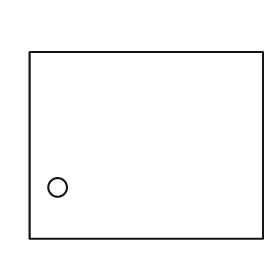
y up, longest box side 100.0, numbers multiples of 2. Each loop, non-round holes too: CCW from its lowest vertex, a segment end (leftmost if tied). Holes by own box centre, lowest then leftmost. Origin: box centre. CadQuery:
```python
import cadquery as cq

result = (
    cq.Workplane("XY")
    .moveTo(-50.0, -40.0)
    .lineTo(50.0, -40.0)
    .lineTo(50.0, 40.0)
    .lineTo(-50.0, 40.0)
    .close()
    .moveTo(-38.0, -18.0)
    .circle(4.0)
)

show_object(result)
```